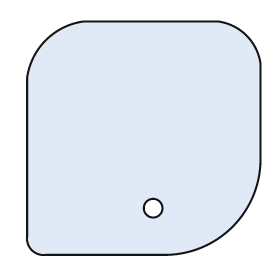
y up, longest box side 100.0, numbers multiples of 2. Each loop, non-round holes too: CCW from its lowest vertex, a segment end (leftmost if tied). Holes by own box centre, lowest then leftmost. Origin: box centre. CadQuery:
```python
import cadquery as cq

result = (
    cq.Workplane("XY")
    .moveTo(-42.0, -50.0)
    .lineTo(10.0, -50.0)
    .threePointArc((38.0, -38.0), (50.0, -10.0))
    .lineTo(50.0, 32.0)
    .threePointArc((44.0, 44.0), (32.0, 50.0))
    .lineTo(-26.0, 50.0)
    .threePointArc((-42.0, 42.0), (-50.0, 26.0))
    .lineTo(-50.0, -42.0)
    .threePointArc((-48.0, -48.0), (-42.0, -50.0))
    .close()
    .moveTo(4.0, -30.0)
    .circle(4.0)
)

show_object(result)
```